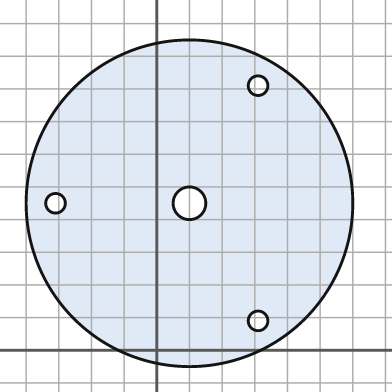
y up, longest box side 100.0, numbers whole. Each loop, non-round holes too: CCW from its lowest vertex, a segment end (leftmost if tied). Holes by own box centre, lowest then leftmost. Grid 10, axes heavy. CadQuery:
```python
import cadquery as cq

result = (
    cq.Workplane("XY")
    .moveTo(10.0, 45.0)
    .circle(50.0)
    .moveTo(31.0, 9.0)
    .circle(3.0)
    .moveTo(-31.0, 45.0)
    .circle(3.0)
    .moveTo(10.0, 45.0)
    .circle(5.0)
    .moveTo(31.0, 81.0)
    .circle(3.0)
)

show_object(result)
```